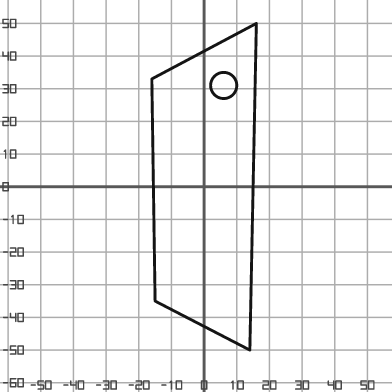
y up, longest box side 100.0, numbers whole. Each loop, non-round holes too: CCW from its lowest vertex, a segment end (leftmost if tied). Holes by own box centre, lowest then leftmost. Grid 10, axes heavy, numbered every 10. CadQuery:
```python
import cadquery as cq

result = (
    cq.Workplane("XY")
    .moveTo(14.0, -50.0)
    .lineTo(16.0, 50.0)
    .lineTo(-16.0, 33.0)
    .lineTo(-15.0, -35.0)
    .close()
    .moveTo(6.0, 31.0)
    .circle(4.0)
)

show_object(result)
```